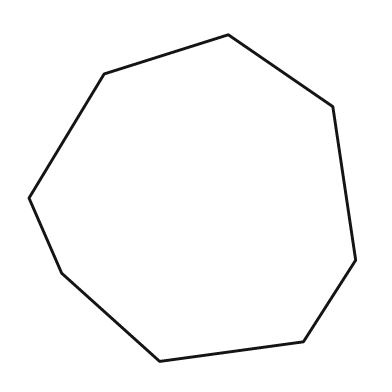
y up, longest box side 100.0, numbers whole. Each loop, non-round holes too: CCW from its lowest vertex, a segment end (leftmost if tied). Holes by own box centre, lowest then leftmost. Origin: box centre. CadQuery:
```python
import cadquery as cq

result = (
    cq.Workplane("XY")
    .moveTo(-10.0, -50.0)
    .lineTo(34.0, -44.0)
    .lineTo(50.0, -19.0)
    .lineTo(43.0, 28.0)
    .lineTo(11.0, 50.0)
    .lineTo(-27.0, 38.0)
    .lineTo(-50.0, 0.0)
    .lineTo(-40.0, -23.0)
    .close()
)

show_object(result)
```